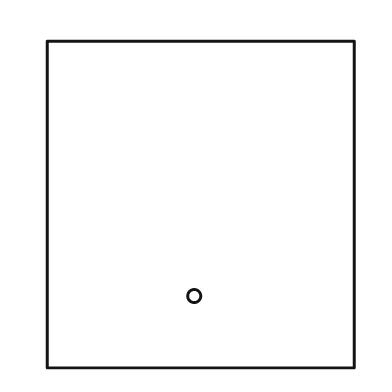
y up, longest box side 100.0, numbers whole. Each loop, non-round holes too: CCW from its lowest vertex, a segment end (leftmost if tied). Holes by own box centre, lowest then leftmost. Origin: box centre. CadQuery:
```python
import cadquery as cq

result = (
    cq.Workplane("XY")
    .moveTo(-47.0, -50.0)
    .lineTo(47.0, -50.0)
    .lineTo(47.0, 50.0)
    .lineTo(-47.0, 50.0)
    .close()
    .moveTo(-2.0, -28.0)
    .circle(2.0)
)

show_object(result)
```